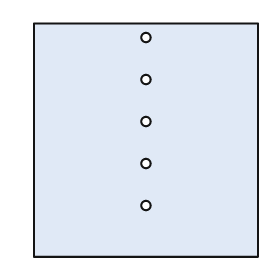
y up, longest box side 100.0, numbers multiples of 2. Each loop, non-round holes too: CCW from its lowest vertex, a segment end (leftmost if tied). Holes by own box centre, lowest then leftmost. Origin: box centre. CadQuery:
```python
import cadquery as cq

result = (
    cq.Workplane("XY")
    .moveTo(-48.0, -50.0)
    .lineTo(48.0, -50.0)
    .lineTo(48.0, 50.0)
    .lineTo(-48.0, 50.0)
    .close()
    .moveTo(0.0, -28.0)
    .circle(2.0)
    .moveTo(0.0, -10.0)
    .circle(2.0)
    .moveTo(0.0, 8.0)
    .circle(2.0)
    .moveTo(0.0, 26.0)
    .circle(2.0)
    .moveTo(0.0, 44.0)
    .circle(2.0)
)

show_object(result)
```